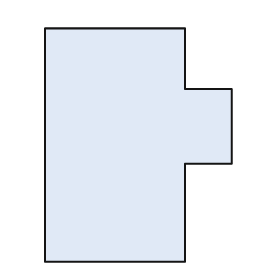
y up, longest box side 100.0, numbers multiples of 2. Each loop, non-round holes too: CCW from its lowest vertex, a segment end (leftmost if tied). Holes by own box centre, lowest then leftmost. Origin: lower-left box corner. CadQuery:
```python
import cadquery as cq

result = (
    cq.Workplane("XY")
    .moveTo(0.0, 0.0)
    .lineTo(60.0, 0.0)
    .lineTo(60.0, 42.0)
    .lineTo(80.0, 42.0)
    .lineTo(80.0, 74.0)
    .lineTo(60.0, 74.0)
    .lineTo(60.0, 100.0)
    .lineTo(0.0, 100.0)
    .close()
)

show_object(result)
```